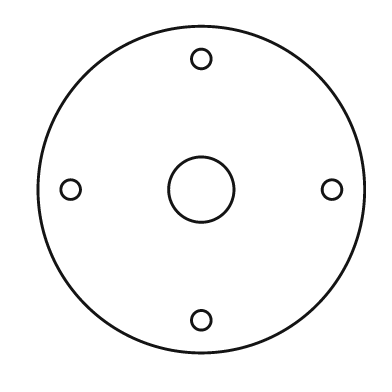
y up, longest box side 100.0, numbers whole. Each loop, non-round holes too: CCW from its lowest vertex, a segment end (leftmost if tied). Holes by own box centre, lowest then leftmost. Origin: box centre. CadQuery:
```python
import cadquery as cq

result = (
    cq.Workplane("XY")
    .moveTo(0.0, 0.0)
    .circle(50.0)
    .moveTo(0.0, -40.0)
    .circle(3.0)
    .moveTo(-40.0, 0.0)
    .circle(3.0)
    .moveTo(0.0, 0.0)
    .circle(10.0)
    .moveTo(40.0, 0.0)
    .circle(3.0)
    .moveTo(0.0, 40.0)
    .circle(3.0)
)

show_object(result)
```